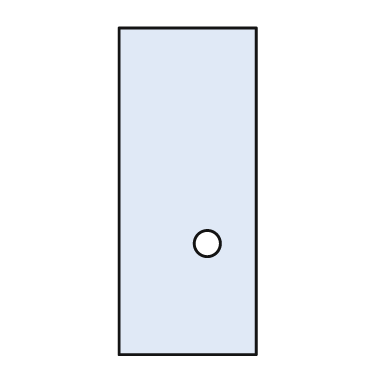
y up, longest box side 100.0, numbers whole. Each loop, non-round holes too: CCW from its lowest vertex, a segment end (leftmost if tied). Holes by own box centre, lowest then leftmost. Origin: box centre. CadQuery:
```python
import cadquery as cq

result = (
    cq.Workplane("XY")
    .moveTo(-21.0, -50.0)
    .lineTo(21.0, -50.0)
    .lineTo(21.0, 50.0)
    .lineTo(-21.0, 50.0)
    .close()
    .moveTo(6.0, -16.0)
    .circle(4.0)
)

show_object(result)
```